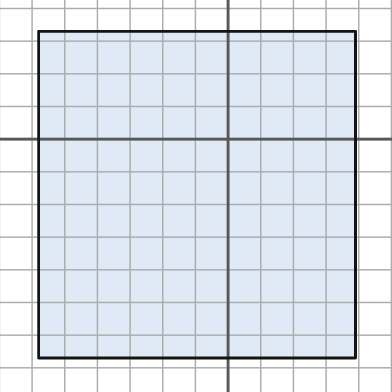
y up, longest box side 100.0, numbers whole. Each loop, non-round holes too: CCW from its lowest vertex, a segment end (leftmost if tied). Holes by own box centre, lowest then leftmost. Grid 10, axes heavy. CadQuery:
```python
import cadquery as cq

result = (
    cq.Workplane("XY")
    .moveTo(-58.0, -67.0)
    .lineTo(39.0, -67.0)
    .lineTo(39.0, 33.0)
    .lineTo(-58.0, 33.0)
    .close()
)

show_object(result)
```